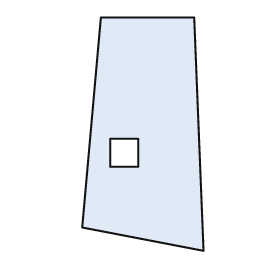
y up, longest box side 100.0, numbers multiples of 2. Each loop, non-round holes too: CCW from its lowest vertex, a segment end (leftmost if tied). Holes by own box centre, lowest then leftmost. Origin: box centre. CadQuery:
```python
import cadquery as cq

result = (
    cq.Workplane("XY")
    .moveTo(26.0, -50.0)
    .lineTo(22.0, 50.0)
    .lineTo(-18.0, 50.0)
    .lineTo(-26.0, -40.0)
    .close()
    .moveTo(-14.0, -14.0)
    .lineTo(-2.0, -14.0)
    .lineTo(-2.0, -2.0)
    .lineTo(-14.0, -2.0)
    .close()
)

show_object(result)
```